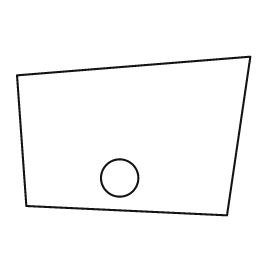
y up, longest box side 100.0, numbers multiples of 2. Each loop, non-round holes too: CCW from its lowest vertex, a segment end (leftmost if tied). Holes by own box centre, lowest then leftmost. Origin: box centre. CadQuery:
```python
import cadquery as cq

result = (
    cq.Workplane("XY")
    .moveTo(40.0, -34.0)
    .lineTo(50.0, 34.0)
    .lineTo(-50.0, 26.0)
    .lineTo(-46.0, -30.0)
    .close()
    .moveTo(-6.0, -18.0)
    .circle(8.0)
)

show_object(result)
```